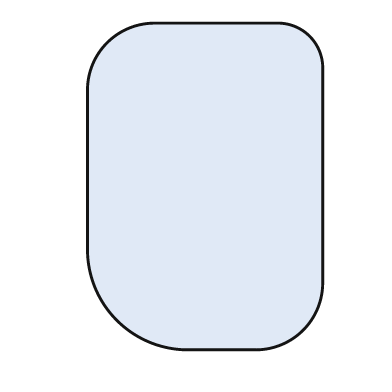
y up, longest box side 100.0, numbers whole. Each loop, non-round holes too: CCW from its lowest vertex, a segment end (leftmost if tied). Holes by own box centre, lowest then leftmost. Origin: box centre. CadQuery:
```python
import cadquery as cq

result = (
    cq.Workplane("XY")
    .moveTo(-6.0, -50.0)
    .lineTo(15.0, -50.0)
    .threePointArc((30.0, -44.0), (36.0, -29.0))
    .lineTo(36.0, 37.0)
    .threePointArc((32.0, 46.0), (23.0, 50.0))
    .lineTo(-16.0, 50.0)
    .threePointArc((-30.0, 44.0), (-36.0, 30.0))
    .lineTo(-36.0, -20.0)
    .threePointArc((-27.0, -41.0), (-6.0, -50.0))
    .close()
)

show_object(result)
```